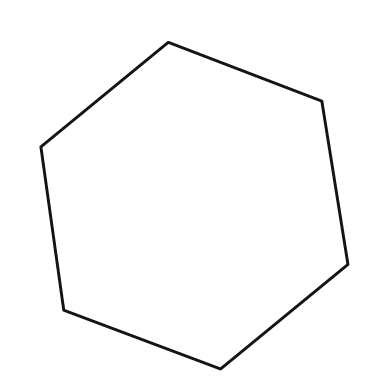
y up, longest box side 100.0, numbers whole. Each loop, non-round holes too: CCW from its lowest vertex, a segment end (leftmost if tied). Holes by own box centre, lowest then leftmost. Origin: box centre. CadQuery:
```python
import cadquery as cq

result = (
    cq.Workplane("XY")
    .moveTo(8.0, -50.0)
    .lineTo(47.0, -18.0)
    .lineTo(39.0, 32.0)
    .lineTo(-8.0, 50.0)
    .lineTo(-47.0, 18.0)
    .lineTo(-40.0, -32.0)
    .close()
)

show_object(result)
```